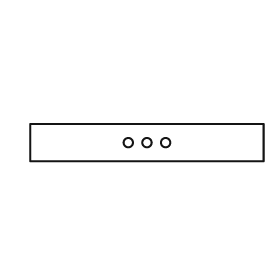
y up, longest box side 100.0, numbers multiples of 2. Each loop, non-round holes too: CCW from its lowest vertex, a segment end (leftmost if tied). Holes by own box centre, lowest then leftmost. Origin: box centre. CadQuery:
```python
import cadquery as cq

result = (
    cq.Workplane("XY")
    .moveTo(-50.0, -8.0)
    .lineTo(50.0, -8.0)
    .lineTo(50.0, 8.0)
    .lineTo(-50.0, 8.0)
    .close()
    .moveTo(-8.0, 0.0)
    .circle(2.0)
    .moveTo(0.0, 0.0)
    .circle(2.0)
    .moveTo(8.0, 0.0)
    .circle(2.0)
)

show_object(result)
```